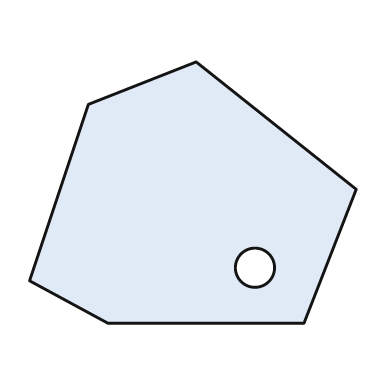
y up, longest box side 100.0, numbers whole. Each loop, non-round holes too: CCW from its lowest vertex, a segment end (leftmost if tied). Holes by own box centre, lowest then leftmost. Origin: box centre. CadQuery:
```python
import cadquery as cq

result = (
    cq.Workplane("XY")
    .moveTo(-26.0, -40.0)
    .lineTo(34.0, -40.0)
    .lineTo(50.0, 1.0)
    .lineTo(1.0, 40.0)
    .lineTo(-32.0, 27.0)
    .lineTo(-50.0, -27.0)
    .close()
    .moveTo(19.0, -23.0)
    .circle(6.0)
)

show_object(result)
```